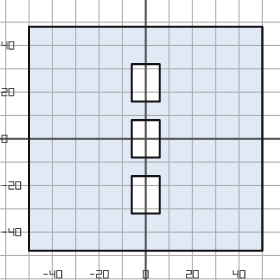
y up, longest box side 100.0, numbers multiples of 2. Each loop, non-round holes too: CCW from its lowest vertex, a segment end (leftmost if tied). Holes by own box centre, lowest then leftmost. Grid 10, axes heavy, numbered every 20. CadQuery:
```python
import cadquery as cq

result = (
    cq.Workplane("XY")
    .moveTo(-50.0, -48.0)
    .lineTo(50.0, -48.0)
    .lineTo(50.0, 48.0)
    .lineTo(-50.0, 48.0)
    .close()
    .moveTo(-6.0, -32.0)
    .lineTo(6.0, -32.0)
    .lineTo(6.0, -16.0)
    .lineTo(-6.0, -16.0)
    .close()
    .moveTo(-6.0, -8.0)
    .lineTo(6.0, -8.0)
    .lineTo(6.0, 8.0)
    .lineTo(-6.0, 8.0)
    .close()
    .moveTo(-6.0, 16.0)
    .lineTo(6.0, 16.0)
    .lineTo(6.0, 32.0)
    .lineTo(-6.0, 32.0)
    .close()
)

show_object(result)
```